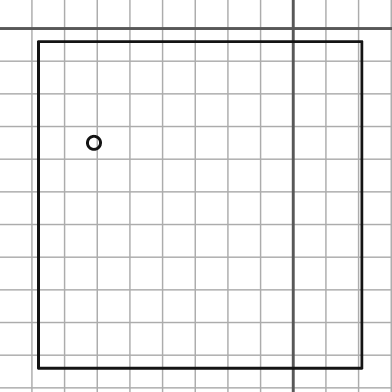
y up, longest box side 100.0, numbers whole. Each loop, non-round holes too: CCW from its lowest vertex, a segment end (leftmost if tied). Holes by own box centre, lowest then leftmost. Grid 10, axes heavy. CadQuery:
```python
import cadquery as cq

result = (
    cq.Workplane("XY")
    .moveTo(-78.0, -104.0)
    .lineTo(21.0, -104.0)
    .lineTo(21.0, -4.0)
    .lineTo(-78.0, -4.0)
    .close()
    .moveTo(-61.0, -35.0)
    .circle(2.0)
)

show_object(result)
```